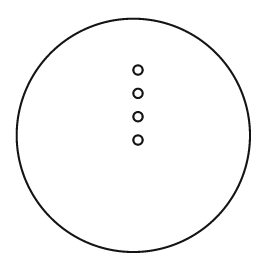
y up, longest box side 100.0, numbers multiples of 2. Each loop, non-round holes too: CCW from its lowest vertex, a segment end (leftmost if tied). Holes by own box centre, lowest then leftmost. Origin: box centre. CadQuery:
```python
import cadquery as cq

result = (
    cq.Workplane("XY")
    .moveTo(0.0, 0.0)
    .circle(50.0)
    .moveTo(2.0, -2.0)
    .circle(2.0)
    .moveTo(2.0, 8.0)
    .circle(2.0)
    .moveTo(2.0, 18.0)
    .circle(2.0)
    .moveTo(2.0, 28.0)
    .circle(2.0)
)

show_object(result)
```